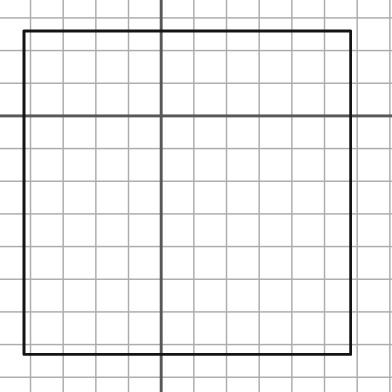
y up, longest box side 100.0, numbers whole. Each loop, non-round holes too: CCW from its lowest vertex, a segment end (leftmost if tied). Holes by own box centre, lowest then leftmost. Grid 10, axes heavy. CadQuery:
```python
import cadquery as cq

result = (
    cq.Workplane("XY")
    .moveTo(-42.0, -73.0)
    .lineTo(58.0, -73.0)
    .lineTo(58.0, 26.0)
    .lineTo(-42.0, 26.0)
    .close()
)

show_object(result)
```